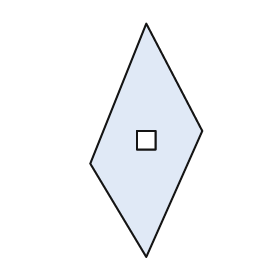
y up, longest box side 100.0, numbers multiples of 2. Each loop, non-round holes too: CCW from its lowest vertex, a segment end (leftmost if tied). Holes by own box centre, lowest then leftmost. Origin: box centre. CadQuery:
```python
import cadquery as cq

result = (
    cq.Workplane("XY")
    .moveTo(0.0, -50.0)
    .lineTo(24.0, 4.0)
    .lineTo(0.0, 50.0)
    .lineTo(-24.0, -10.0)
    .close()
    .moveTo(-4.0, -4.0)
    .lineTo(4.0, -4.0)
    .lineTo(4.0, 4.0)
    .lineTo(-4.0, 4.0)
    .close()
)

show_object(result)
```